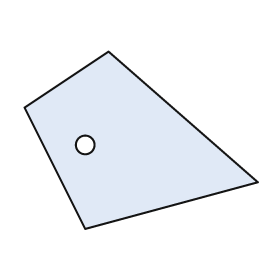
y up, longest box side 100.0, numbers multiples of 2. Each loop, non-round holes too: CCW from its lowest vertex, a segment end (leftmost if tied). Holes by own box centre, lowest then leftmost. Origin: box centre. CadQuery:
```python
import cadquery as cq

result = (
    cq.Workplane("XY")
    .moveTo(-24.0, -38.0)
    .lineTo(50.0, -18.0)
    .lineTo(-14.0, 38.0)
    .lineTo(-50.0, 14.0)
    .close()
    .moveTo(-24.0, -2.0)
    .circle(4.0)
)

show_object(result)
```